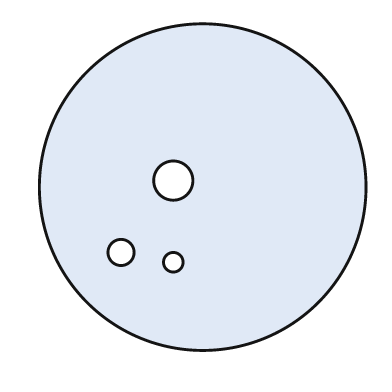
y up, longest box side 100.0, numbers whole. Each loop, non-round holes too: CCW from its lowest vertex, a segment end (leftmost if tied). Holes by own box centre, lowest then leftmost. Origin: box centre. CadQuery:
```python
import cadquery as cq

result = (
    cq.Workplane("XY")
    .moveTo(0.0, 0.0)
    .circle(50.0)
    .moveTo(-9.0, -23.0)
    .circle(3.0)
    .moveTo(-25.0, -20.0)
    .circle(4.0)
    .moveTo(-9.0, 2.0)
    .circle(6.0)
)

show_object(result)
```